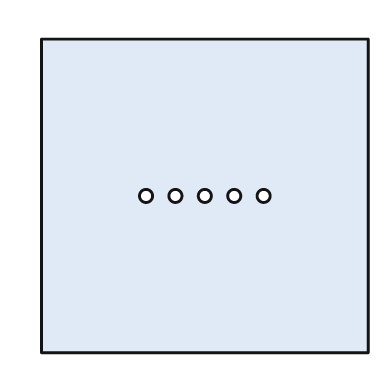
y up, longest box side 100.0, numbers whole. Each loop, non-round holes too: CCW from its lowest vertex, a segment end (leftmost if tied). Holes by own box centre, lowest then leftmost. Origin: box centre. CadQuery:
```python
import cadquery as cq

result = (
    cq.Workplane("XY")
    .moveTo(-50.0, -48.0)
    .lineTo(50.0, -48.0)
    .lineTo(50.0, 48.0)
    .lineTo(-50.0, 48.0)
    .close()
    .moveTo(-18.0, 0.0)
    .circle(2.0)
    .moveTo(-9.0, 0.0)
    .circle(2.0)
    .moveTo(0.0, 0.0)
    .circle(2.0)
    .moveTo(9.0, 0.0)
    .circle(2.0)
    .moveTo(18.0, 0.0)
    .circle(2.0)
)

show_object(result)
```